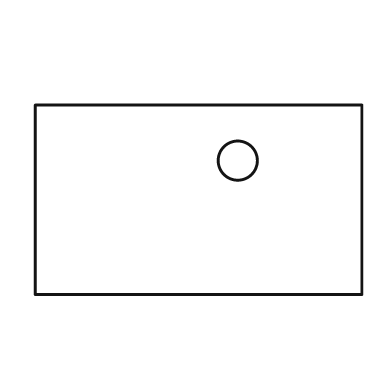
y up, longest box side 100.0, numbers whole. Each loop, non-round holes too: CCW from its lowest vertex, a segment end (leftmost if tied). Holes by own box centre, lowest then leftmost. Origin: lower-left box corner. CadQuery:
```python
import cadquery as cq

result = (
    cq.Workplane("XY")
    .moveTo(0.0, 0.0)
    .lineTo(100.0, 0.0)
    .lineTo(100.0, 58.0)
    .lineTo(0.0, 58.0)
    .close()
    .moveTo(62.0, 41.0)
    .circle(6.0)
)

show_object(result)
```